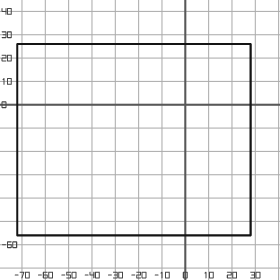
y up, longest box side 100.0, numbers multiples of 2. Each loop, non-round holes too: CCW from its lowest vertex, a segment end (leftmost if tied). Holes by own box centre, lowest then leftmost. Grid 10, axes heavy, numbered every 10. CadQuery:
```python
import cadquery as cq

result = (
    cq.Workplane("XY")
    .moveTo(-72.0, -56.0)
    .lineTo(28.0, -56.0)
    .lineTo(28.0, 26.0)
    .lineTo(-72.0, 26.0)
    .close()
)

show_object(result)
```